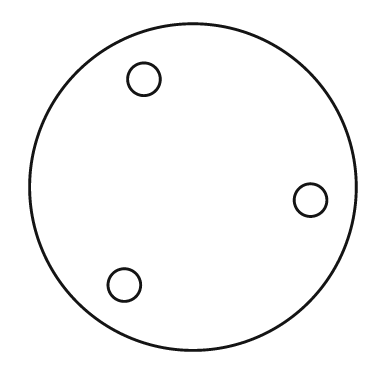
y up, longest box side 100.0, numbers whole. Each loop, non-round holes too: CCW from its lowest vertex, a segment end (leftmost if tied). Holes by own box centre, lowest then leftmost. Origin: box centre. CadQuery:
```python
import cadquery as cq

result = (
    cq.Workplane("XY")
    .moveTo(0.0, 0.0)
    .circle(50.0)
    .moveTo(-21.0, -30.0)
    .circle(5.0)
    .moveTo(36.0, -4.0)
    .circle(5.0)
    .moveTo(-15.0, 33.0)
    .circle(5.0)
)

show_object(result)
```